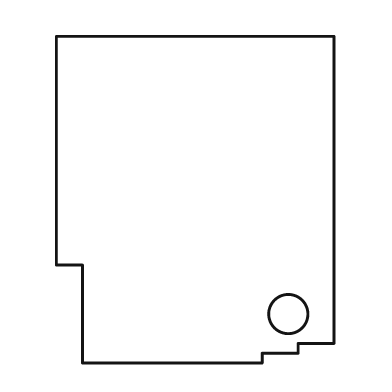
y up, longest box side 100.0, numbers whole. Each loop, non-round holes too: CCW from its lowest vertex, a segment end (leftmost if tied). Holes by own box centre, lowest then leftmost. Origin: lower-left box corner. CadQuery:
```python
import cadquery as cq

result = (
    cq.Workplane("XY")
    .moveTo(8.0, 0.0)
    .lineTo(63.0, 0.0)
    .lineTo(63.0, 3.0)
    .lineTo(74.0, 3.0)
    .lineTo(74.0, 6.0)
    .lineTo(85.0, 6.0)
    .lineTo(85.0, 100.0)
    .lineTo(0.0, 100.0)
    .lineTo(0.0, 30.0)
    .lineTo(8.0, 30.0)
    .close()
    .moveTo(71.0, 15.0)
    .circle(6.0)
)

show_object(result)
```